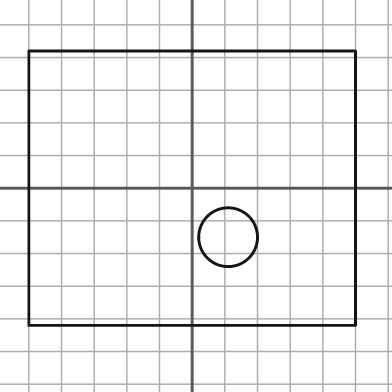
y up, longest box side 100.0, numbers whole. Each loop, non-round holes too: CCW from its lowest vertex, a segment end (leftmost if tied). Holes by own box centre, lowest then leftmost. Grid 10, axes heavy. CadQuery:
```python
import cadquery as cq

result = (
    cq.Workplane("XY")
    .moveTo(-50.0, -42.0)
    .lineTo(50.0, -42.0)
    .lineTo(50.0, 42.0)
    .lineTo(-50.0, 42.0)
    .close()
    .moveTo(11.0, -15.0)
    .circle(9.0)
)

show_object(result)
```